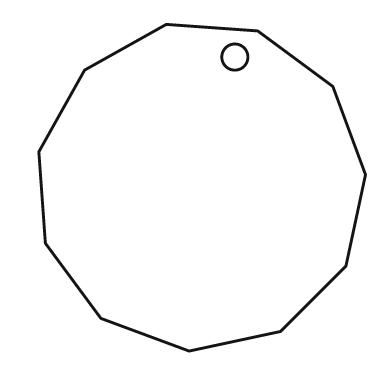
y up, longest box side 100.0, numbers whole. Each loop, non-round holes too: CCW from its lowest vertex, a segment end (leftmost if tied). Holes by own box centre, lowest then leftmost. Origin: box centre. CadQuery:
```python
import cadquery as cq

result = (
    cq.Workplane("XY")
    .moveTo(-4.0, -50.0)
    .lineTo(24.0, -44.0)
    .lineTo(44.0, -24.0)
    .lineTo(50.0, 4.0)
    .lineTo(40.0, 31.0)
    .lineTo(17.0, 48.0)
    .lineTo(-11.0, 50.0)
    .lineTo(-36.0, 36.0)
    .lineTo(-50.0, 11.0)
    .lineTo(-48.0, -17.0)
    .lineTo(-31.0, -40.0)
    .close()
    .moveTo(10.0, 40.0)
    .circle(4.0)
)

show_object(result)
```